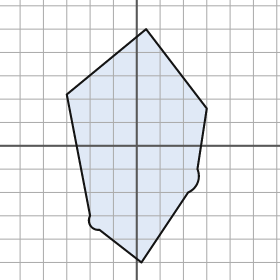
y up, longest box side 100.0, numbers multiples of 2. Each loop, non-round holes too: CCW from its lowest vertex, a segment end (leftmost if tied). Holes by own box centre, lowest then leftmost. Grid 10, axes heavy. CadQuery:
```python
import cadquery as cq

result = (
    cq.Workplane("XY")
    .moveTo(2.0, -50.0)
    .lineTo(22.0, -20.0)
    .threePointArc((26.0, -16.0), (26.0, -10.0))
    .lineTo(30.0, 16.0)
    .lineTo(4.0, 50.0)
    .lineTo(-30.0, 22.0)
    .lineTo(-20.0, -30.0)
    .threePointArc((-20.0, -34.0), (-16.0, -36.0))
    .close()
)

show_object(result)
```